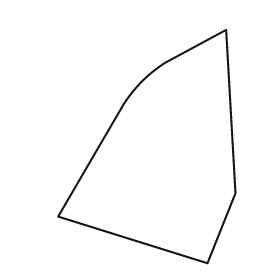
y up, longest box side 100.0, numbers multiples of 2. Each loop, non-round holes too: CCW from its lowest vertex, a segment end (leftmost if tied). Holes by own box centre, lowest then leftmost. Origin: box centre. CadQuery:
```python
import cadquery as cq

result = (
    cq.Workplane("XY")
    .moveTo(26.0, -50.0)
    .lineTo(38.0, -20.0)
    .lineTo(34.0, 50.0)
    .lineTo(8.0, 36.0)
    .threePointArc((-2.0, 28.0), (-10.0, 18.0))
    .lineTo(-38.0, -30.0)
    .close()
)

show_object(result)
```